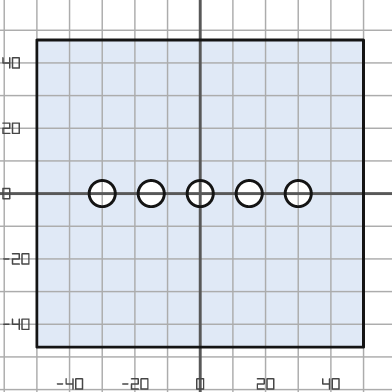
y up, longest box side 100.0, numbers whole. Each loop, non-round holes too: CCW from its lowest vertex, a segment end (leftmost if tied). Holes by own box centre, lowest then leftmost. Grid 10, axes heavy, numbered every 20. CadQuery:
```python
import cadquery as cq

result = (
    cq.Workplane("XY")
    .moveTo(-50.0, -47.0)
    .lineTo(50.0, -47.0)
    .lineTo(50.0, 47.0)
    .lineTo(-50.0, 47.0)
    .close()
    .moveTo(-30.0, 0.0)
    .circle(4.0)
    .moveTo(-15.0, 0.0)
    .circle(4.0)
    .moveTo(0.0, 0.0)
    .circle(4.0)
    .moveTo(15.0, 0.0)
    .circle(4.0)
    .moveTo(30.0, 0.0)
    .circle(4.0)
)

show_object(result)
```